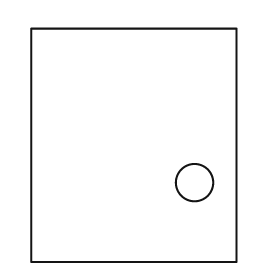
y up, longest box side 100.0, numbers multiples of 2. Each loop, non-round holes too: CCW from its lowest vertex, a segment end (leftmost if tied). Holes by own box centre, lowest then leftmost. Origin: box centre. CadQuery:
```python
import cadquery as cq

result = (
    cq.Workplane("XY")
    .moveTo(-44.0, -50.0)
    .lineTo(44.0, -50.0)
    .lineTo(44.0, 50.0)
    .lineTo(-44.0, 50.0)
    .close()
    .moveTo(26.0, -16.0)
    .circle(8.0)
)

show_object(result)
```